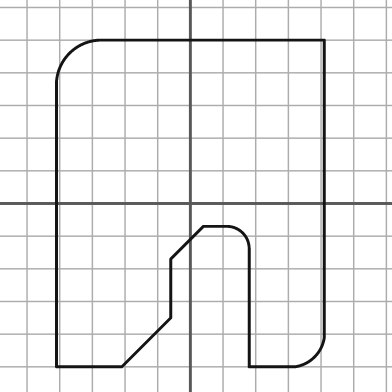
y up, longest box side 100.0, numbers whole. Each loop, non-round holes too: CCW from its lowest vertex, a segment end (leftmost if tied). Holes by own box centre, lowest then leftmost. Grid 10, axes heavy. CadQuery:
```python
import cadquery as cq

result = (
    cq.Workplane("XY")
    .moveTo(-41.0, -50.0)
    .lineTo(-21.0, -50.0)
    .lineTo(-6.0, -35.0)
    .lineTo(-6.0, -17.0)
    .lineTo(4.0, -7.0)
    .lineTo(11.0, -7.0)
    .threePointArc((16.0, -9.0), (18.0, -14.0))
    .lineTo(18.0, -50.0)
    .lineTo(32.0, -50.0)
    .threePointArc((38.0, -47.0), (41.0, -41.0))
    .lineTo(41.0, 50.0)
    .lineTo(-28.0, 50.0)
    .threePointArc((-37.0, 46.0), (-41.0, 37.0))
    .close()
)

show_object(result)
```